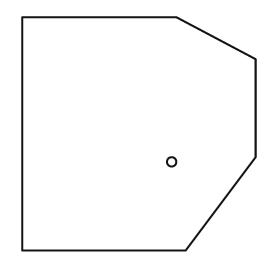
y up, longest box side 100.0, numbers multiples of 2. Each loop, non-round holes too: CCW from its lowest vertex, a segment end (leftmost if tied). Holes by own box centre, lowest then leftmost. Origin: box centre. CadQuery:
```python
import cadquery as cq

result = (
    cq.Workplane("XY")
    .moveTo(-50.0, -50.0)
    .lineTo(20.0, -50.0)
    .lineTo(50.0, -10.0)
    .lineTo(50.0, 32.0)
    .lineTo(16.0, 50.0)
    .lineTo(-50.0, 50.0)
    .close()
    .moveTo(14.0, -12.0)
    .circle(2.0)
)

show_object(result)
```